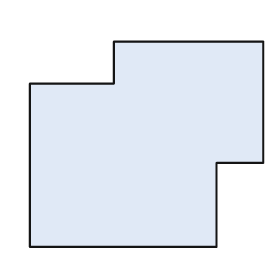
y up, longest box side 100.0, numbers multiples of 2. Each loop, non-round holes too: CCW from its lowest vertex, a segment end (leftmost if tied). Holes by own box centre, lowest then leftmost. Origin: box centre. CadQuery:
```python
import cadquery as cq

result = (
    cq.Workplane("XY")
    .moveTo(-50.0, -44.0)
    .lineTo(30.0, -44.0)
    .lineTo(30.0, -8.0)
    .lineTo(50.0, -8.0)
    .lineTo(50.0, 44.0)
    .lineTo(-14.0, 44.0)
    .lineTo(-14.0, 26.0)
    .lineTo(-50.0, 26.0)
    .close()
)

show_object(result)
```